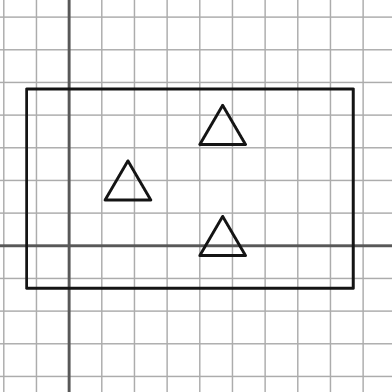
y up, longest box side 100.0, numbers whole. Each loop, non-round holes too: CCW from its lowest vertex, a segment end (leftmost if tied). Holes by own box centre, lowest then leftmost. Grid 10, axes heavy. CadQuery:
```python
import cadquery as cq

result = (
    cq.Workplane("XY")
    .moveTo(-13.0, -13.0)
    .lineTo(87.0, -13.0)
    .lineTo(87.0, 48.0)
    .lineTo(-13.0, 48.0)
    .close()
    .moveTo(40.0, -3.0)
    .lineTo(54.0, -3.0)
    .lineTo(47.0, 9.0)
    .close()
    .moveTo(11.0, 14.0)
    .lineTo(25.0, 14.0)
    .lineTo(18.0, 26.0)
    .close()
    .moveTo(40.0, 31.0)
    .lineTo(54.0, 31.0)
    .lineTo(47.0, 43.0)
    .close()
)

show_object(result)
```